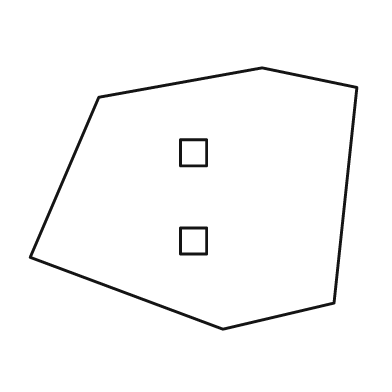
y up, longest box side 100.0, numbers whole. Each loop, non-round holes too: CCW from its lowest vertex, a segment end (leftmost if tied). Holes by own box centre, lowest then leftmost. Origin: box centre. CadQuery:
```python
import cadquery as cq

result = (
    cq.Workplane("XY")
    .moveTo(9.0, -40.0)
    .lineTo(43.0, -32.0)
    .lineTo(50.0, 34.0)
    .lineTo(21.0, 40.0)
    .lineTo(-29.0, 31.0)
    .lineTo(-50.0, -18.0)
    .close()
    .moveTo(-4.0, -17.0)
    .lineTo(4.0, -17.0)
    .lineTo(4.0, -9.0)
    .lineTo(-4.0, -9.0)
    .close()
    .moveTo(-4.0, 10.0)
    .lineTo(4.0, 10.0)
    .lineTo(4.0, 18.0)
    .lineTo(-4.0, 18.0)
    .close()
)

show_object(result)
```